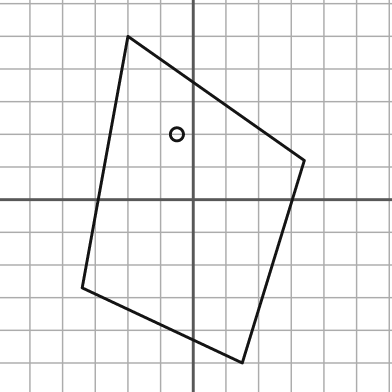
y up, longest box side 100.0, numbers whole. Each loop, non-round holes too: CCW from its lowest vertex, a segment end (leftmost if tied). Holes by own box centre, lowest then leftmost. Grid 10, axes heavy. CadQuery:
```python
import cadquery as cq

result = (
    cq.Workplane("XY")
    .moveTo(15.0, -50.0)
    .lineTo(34.0, 12.0)
    .lineTo(-20.0, 50.0)
    .lineTo(-34.0, -27.0)
    .close()
    .moveTo(-5.0, 20.0)
    .circle(2.0)
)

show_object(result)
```